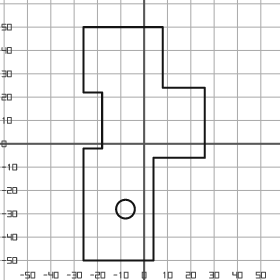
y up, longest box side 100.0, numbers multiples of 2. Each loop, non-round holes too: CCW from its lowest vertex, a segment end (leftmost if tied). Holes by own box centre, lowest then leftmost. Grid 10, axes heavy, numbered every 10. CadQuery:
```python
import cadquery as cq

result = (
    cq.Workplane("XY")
    .moveTo(-26.0, -50.0)
    .lineTo(4.0, -50.0)
    .lineTo(4.0, -6.0)
    .lineTo(26.0, -6.0)
    .lineTo(26.0, 24.0)
    .lineTo(8.0, 24.0)
    .lineTo(8.0, 50.0)
    .lineTo(-26.0, 50.0)
    .lineTo(-26.0, 22.0)
    .lineTo(-18.0, 22.0)
    .lineTo(-18.0, -2.0)
    .lineTo(-26.0, -2.0)
    .close()
    .moveTo(-8.0, -28.0)
    .circle(4.0)
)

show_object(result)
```